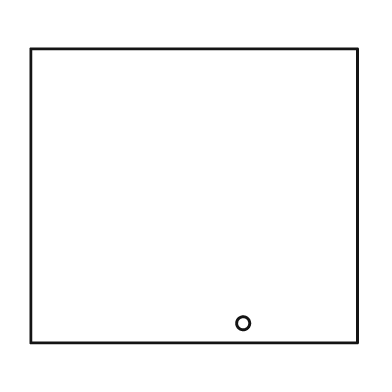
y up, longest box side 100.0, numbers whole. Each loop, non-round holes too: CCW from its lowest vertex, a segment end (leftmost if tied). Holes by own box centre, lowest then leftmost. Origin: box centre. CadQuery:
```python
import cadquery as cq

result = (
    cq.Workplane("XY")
    .moveTo(-50.0, -45.0)
    .lineTo(50.0, -45.0)
    .lineTo(50.0, 45.0)
    .lineTo(-50.0, 45.0)
    .close()
    .moveTo(15.0, -39.0)
    .circle(2.0)
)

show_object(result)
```